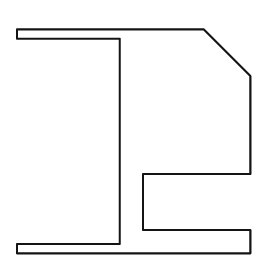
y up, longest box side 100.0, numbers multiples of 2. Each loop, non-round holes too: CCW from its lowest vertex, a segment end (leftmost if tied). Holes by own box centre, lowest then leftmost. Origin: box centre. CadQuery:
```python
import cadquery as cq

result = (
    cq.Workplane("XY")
    .moveTo(-50.0, -48.0)
    .lineTo(50.0, -48.0)
    .lineTo(50.0, -38.0)
    .lineTo(4.0, -38.0)
    .lineTo(4.0, -14.0)
    .lineTo(50.0, -14.0)
    .lineTo(50.0, 28.0)
    .lineTo(30.0, 48.0)
    .lineTo(-50.0, 48.0)
    .lineTo(-50.0, 44.0)
    .lineTo(-6.0, 44.0)
    .lineTo(-6.0, -44.0)
    .lineTo(-50.0, -44.0)
    .close()
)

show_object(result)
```